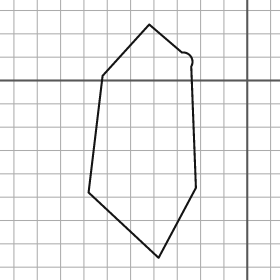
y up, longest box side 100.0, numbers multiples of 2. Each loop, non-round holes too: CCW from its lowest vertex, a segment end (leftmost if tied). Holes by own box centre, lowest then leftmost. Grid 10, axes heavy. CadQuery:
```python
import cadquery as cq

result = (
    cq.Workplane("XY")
    .moveTo(-38.0, -76.0)
    .lineTo(-22.0, -46.0)
    .lineTo(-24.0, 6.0)
    .threePointArc((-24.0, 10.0), (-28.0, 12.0))
    .lineTo(-42.0, 24.0)
    .lineTo(-62.0, 2.0)
    .lineTo(-68.0, -48.0)
    .close()
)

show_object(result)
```